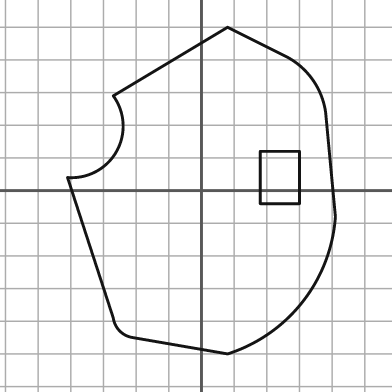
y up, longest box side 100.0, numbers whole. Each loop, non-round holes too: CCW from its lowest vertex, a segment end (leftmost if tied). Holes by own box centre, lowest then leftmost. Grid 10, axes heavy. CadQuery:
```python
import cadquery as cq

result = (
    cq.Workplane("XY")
    .moveTo(8.0, -50.0)
    .threePointArc((31.0, -34.0), (41.0, -8.0))
    .lineTo(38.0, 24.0)
    .threePointArc((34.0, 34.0), (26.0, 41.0))
    .lineTo(8.0, 50.0)
    .lineTo(-27.0, 29.0)
    .threePointArc((-26.0, 12.0), (-41.0, 4.0))
    .lineTo(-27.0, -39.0)
    .threePointArc((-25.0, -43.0), (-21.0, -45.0))
    .close()
    .moveTo(18.0, -4.0)
    .lineTo(30.0, -4.0)
    .lineTo(30.0, 12.0)
    .lineTo(18.0, 12.0)
    .close()
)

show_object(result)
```